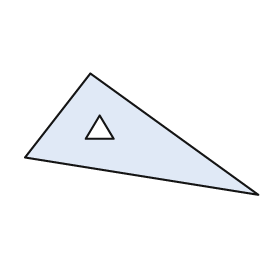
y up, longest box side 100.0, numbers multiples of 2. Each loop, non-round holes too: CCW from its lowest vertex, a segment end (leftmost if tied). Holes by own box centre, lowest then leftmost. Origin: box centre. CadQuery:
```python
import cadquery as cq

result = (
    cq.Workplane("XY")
    .moveTo(50.0, -26.0)
    .lineTo(-22.0, 26.0)
    .lineTo(-50.0, -10.0)
    .close()
    .moveTo(-24.0, -2.0)
    .lineTo(-12.0, -2.0)
    .lineTo(-18.0, 8.0)
    .close()
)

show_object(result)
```